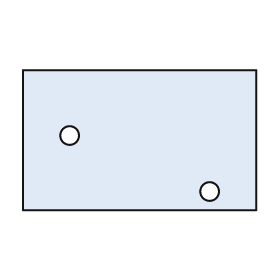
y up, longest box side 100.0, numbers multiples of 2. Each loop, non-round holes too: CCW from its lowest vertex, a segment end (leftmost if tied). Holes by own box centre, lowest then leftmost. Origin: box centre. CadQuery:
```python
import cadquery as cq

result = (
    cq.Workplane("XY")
    .moveTo(-50.0, -30.0)
    .lineTo(50.0, -30.0)
    .lineTo(50.0, 30.0)
    .lineTo(-50.0, 30.0)
    .close()
    .moveTo(30.0, -22.0)
    .circle(4.0)
    .moveTo(-30.0, 2.0)
    .circle(4.0)
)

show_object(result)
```